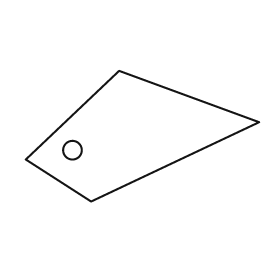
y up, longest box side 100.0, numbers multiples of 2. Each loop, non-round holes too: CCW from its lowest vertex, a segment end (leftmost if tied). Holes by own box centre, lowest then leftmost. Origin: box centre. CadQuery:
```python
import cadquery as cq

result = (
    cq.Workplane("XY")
    .moveTo(-22.0, -28.0)
    .lineTo(50.0, 6.0)
    .lineTo(-10.0, 28.0)
    .lineTo(-50.0, -10.0)
    .close()
    .moveTo(-30.0, -6.0)
    .circle(4.0)
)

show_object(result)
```